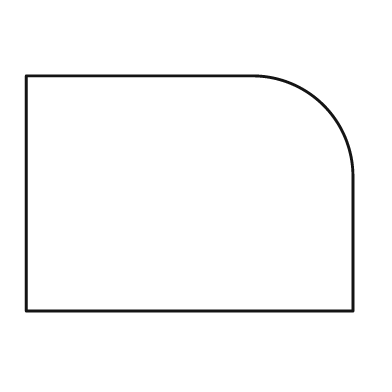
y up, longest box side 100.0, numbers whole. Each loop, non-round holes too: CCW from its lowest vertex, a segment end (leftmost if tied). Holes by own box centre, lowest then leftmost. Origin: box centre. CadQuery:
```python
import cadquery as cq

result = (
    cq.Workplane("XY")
    .moveTo(-50.0, -36.0)
    .lineTo(50.0, -36.0)
    .lineTo(50.0, 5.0)
    .threePointArc((41.0, 27.0), (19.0, 36.0))
    .lineTo(-50.0, 36.0)
    .close()
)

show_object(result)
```